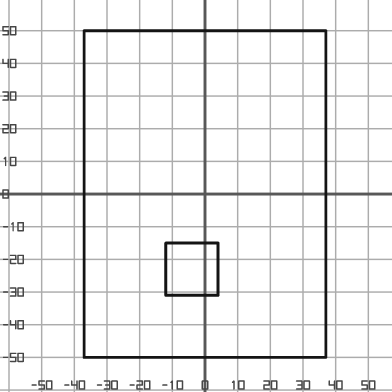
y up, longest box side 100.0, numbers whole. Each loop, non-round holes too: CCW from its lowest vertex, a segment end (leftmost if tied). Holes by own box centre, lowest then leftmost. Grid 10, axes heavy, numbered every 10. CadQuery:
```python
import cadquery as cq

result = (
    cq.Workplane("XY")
    .moveTo(-37.0, -50.0)
    .lineTo(37.0, -50.0)
    .lineTo(37.0, 50.0)
    .lineTo(-37.0, 50.0)
    .close()
    .moveTo(-12.0, -31.0)
    .lineTo(4.0, -31.0)
    .lineTo(4.0, -15.0)
    .lineTo(-12.0, -15.0)
    .close()
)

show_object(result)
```